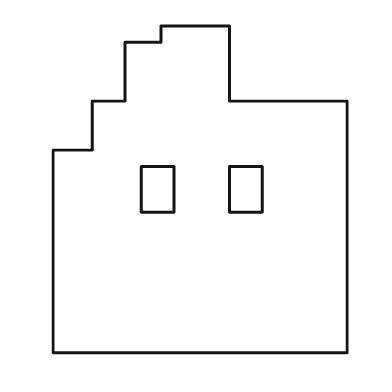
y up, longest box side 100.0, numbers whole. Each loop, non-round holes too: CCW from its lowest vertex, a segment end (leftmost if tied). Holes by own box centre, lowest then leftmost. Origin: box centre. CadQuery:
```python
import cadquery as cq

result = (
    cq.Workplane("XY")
    .moveTo(-45.0, -50.0)
    .lineTo(45.0, -50.0)
    .lineTo(45.0, 27.0)
    .lineTo(9.0, 27.0)
    .lineTo(9.0, 50.0)
    .lineTo(-12.0, 50.0)
    .lineTo(-12.0, 45.0)
    .lineTo(-23.0, 45.0)
    .lineTo(-23.0, 27.0)
    .lineTo(-33.0, 27.0)
    .lineTo(-33.0, 12.0)
    .lineTo(-45.0, 12.0)
    .close()
    .moveTo(-18.0, -7.0)
    .lineTo(-8.0, -7.0)
    .lineTo(-8.0, 7.0)
    .lineTo(-18.0, 7.0)
    .close()
    .moveTo(9.0, -7.0)
    .lineTo(19.0, -7.0)
    .lineTo(19.0, 7.0)
    .lineTo(9.0, 7.0)
    .close()
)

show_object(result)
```